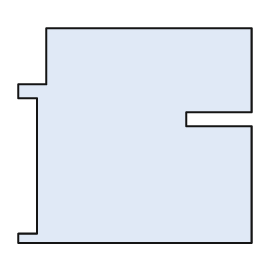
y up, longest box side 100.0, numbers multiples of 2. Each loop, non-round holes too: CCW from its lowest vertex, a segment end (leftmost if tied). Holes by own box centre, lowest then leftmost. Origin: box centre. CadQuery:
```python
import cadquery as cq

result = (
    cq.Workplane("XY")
    .moveTo(-50.0, -46.0)
    .lineTo(50.0, -46.0)
    .lineTo(50.0, 4.0)
    .lineTo(22.0, 4.0)
    .lineTo(22.0, 10.0)
    .lineTo(50.0, 10.0)
    .lineTo(50.0, 46.0)
    .lineTo(-38.0, 46.0)
    .lineTo(-38.0, 22.0)
    .lineTo(-50.0, 22.0)
    .lineTo(-50.0, 16.0)
    .lineTo(-42.0, 16.0)
    .lineTo(-42.0, -42.0)
    .lineTo(-50.0, -42.0)
    .close()
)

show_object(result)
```